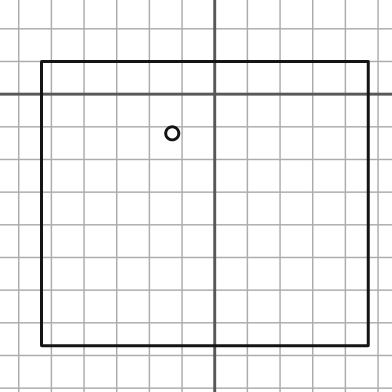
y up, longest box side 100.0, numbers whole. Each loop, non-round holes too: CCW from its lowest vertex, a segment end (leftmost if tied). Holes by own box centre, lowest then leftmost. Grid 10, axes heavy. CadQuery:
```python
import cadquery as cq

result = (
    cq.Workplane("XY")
    .moveTo(-53.0, -77.0)
    .lineTo(47.0, -77.0)
    .lineTo(47.0, 10.0)
    .lineTo(-53.0, 10.0)
    .close()
    .moveTo(-13.0, -12.0)
    .circle(2.0)
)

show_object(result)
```